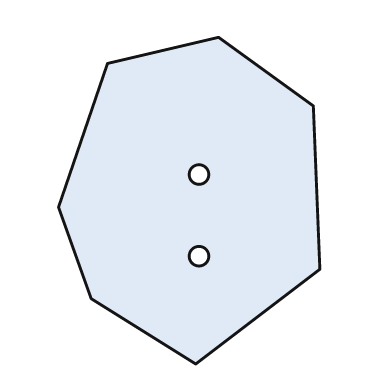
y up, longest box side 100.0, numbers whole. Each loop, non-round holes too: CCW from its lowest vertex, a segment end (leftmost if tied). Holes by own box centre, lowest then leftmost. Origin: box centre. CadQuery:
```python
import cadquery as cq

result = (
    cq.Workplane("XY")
    .moveTo(2.0, -50.0)
    .lineTo(40.0, -21.0)
    .lineTo(38.0, 29.0)
    .lineTo(9.0, 50.0)
    .lineTo(-25.0, 42.0)
    .lineTo(-40.0, -2.0)
    .lineTo(-30.0, -30.0)
    .close()
    .moveTo(3.0, -17.0)
    .circle(3.0)
    .moveTo(3.0, 8.0)
    .circle(3.0)
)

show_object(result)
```